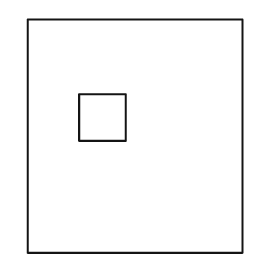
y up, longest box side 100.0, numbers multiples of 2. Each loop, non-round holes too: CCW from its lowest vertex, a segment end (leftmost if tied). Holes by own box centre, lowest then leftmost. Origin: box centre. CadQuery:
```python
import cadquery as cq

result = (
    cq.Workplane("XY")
    .moveTo(-46.0, -50.0)
    .lineTo(46.0, -50.0)
    .lineTo(46.0, 50.0)
    .lineTo(-46.0, 50.0)
    .close()
    .moveTo(-24.0, -2.0)
    .lineTo(-4.0, -2.0)
    .lineTo(-4.0, 18.0)
    .lineTo(-24.0, 18.0)
    .close()
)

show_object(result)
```